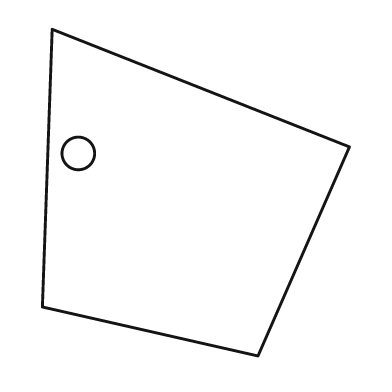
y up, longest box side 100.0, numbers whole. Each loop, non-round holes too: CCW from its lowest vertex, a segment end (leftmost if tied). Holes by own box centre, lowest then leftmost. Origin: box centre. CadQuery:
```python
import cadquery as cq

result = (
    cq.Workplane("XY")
    .moveTo(19.0, -50.0)
    .lineTo(47.0, 14.0)
    .lineTo(-44.0, 50.0)
    .lineTo(-47.0, -35.0)
    .close()
    .moveTo(-36.0, 12.0)
    .circle(5.0)
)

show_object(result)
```